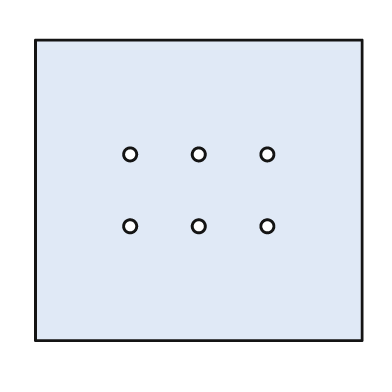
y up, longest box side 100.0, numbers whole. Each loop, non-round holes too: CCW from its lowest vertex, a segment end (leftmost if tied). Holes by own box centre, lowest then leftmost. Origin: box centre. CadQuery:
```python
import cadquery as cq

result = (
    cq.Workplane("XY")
    .moveTo(-50.0, -46.0)
    .lineTo(50.0, -46.0)
    .lineTo(50.0, 46.0)
    .lineTo(-50.0, 46.0)
    .close()
    .moveTo(-21.0, -11.0)
    .circle(2.0)
    .moveTo(0.0, -11.0)
    .circle(2.0)
    .moveTo(21.0, -11.0)
    .circle(2.0)
    .moveTo(-21.0, 11.0)
    .circle(2.0)
    .moveTo(0.0, 11.0)
    .circle(2.0)
    .moveTo(21.0, 11.0)
    .circle(2.0)
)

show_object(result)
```